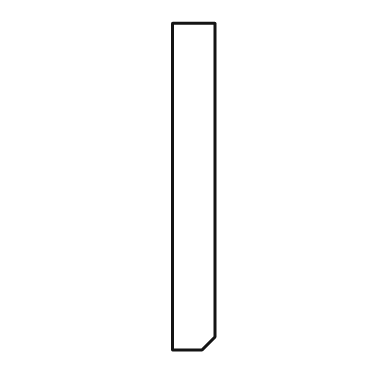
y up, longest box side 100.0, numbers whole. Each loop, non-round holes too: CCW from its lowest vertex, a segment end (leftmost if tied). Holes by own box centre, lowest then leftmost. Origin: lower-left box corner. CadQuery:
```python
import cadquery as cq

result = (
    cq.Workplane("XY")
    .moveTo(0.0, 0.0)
    .lineTo(9.0, 0.0)
    .lineTo(13.0, 4.0)
    .lineTo(13.0, 100.0)
    .lineTo(0.0, 100.0)
    .close()
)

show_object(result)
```